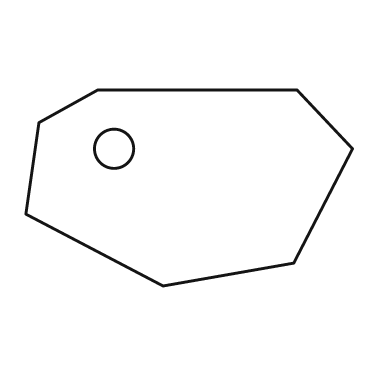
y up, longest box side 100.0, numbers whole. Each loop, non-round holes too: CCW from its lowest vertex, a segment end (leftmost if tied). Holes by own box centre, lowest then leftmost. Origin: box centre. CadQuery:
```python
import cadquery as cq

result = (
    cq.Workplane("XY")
    .moveTo(-8.0, -30.0)
    .lineTo(32.0, -23.0)
    .lineTo(50.0, 12.0)
    .lineTo(33.0, 30.0)
    .lineTo(-28.0, 30.0)
    .lineTo(-46.0, 20.0)
    .lineTo(-50.0, -8.0)
    .close()
    .moveTo(-23.0, 12.0)
    .circle(6.0)
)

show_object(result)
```